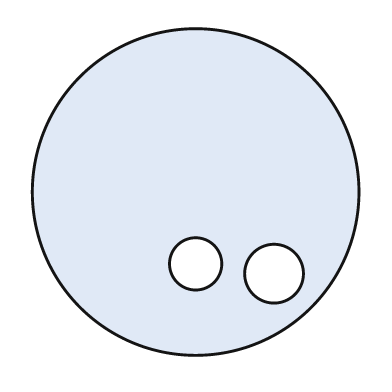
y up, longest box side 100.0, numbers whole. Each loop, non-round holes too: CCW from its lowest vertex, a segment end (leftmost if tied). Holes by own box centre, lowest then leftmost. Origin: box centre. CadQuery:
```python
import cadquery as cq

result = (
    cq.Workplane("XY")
    .moveTo(0.0, 0.0)
    .circle(50.0)
    .moveTo(24.0, -25.0)
    .circle(9.0)
    .moveTo(0.0, -22.0)
    .circle(8.0)
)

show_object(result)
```